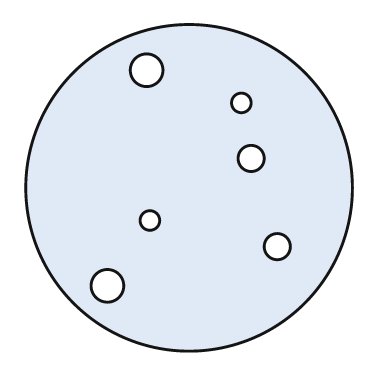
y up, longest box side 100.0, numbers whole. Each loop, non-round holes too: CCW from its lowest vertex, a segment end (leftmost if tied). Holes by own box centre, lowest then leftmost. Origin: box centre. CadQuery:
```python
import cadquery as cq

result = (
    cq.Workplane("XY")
    .moveTo(0.0, 0.0)
    .circle(50.0)
    .moveTo(-25.0, -30.0)
    .circle(5.0)
    .moveTo(27.0, -18.0)
    .circle(4.0)
    .moveTo(-12.0, -10.0)
    .circle(3.0)
    .moveTo(19.0, 9.0)
    .circle(4.0)
    .moveTo(16.0, 26.0)
    .circle(3.0)
    .moveTo(-13.0, 36.0)
    .circle(5.0)
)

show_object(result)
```